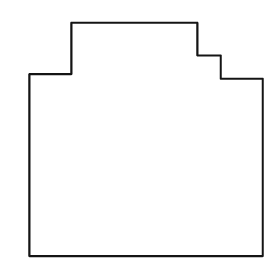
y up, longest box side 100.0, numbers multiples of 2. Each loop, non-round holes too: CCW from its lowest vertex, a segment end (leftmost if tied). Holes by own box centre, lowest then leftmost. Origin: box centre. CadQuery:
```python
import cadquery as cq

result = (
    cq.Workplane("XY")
    .moveTo(-50.0, -50.0)
    .lineTo(50.0, -50.0)
    .lineTo(50.0, 26.0)
    .lineTo(32.0, 26.0)
    .lineTo(32.0, 36.0)
    .lineTo(22.0, 36.0)
    .lineTo(22.0, 50.0)
    .lineTo(-32.0, 50.0)
    .lineTo(-32.0, 28.0)
    .lineTo(-50.0, 28.0)
    .close()
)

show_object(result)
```